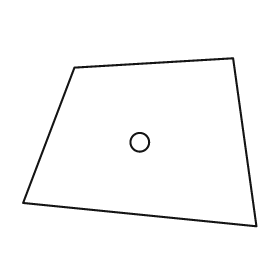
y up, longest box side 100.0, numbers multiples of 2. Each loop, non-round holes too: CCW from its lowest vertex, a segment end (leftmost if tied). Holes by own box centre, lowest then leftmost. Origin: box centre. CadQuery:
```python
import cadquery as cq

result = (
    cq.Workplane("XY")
    .moveTo(50.0, -36.0)
    .lineTo(40.0, 36.0)
    .lineTo(-28.0, 32.0)
    .lineTo(-50.0, -26.0)
    .close()
    .moveTo(0.0, 0.0)
    .circle(4.0)
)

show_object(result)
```